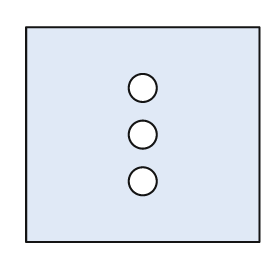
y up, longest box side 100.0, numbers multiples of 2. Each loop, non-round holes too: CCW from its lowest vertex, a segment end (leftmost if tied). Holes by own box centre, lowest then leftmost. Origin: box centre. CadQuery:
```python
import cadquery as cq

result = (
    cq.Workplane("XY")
    .moveTo(-50.0, -46.0)
    .lineTo(50.0, -46.0)
    .lineTo(50.0, 46.0)
    .lineTo(-50.0, 46.0)
    .close()
    .moveTo(0.0, -20.0)
    .circle(6.0)
    .moveTo(0.0, 0.0)
    .circle(6.0)
    .moveTo(0.0, 20.0)
    .circle(6.0)
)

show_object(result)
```